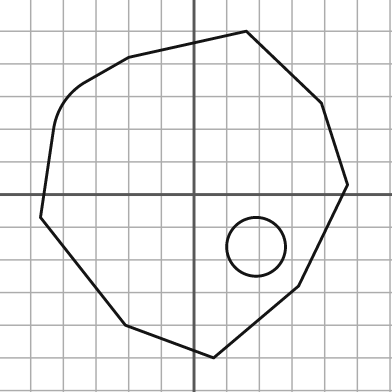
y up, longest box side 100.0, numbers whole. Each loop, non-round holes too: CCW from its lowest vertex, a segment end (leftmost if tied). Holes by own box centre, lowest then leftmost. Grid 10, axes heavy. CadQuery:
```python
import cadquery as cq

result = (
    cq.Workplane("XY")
    .moveTo(6.0, -50.0)
    .lineTo(32.0, -28.0)
    .lineTo(47.0, 3.0)
    .lineTo(39.0, 28.0)
    .lineTo(16.0, 50.0)
    .lineTo(-20.0, 42.0)
    .lineTo(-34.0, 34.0)
    .threePointArc((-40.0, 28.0), (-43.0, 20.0))
    .lineTo(-47.0, -7.0)
    .lineTo(-21.0, -40.0)
    .close()
    .moveTo(19.0, -16.0)
    .circle(9.0)
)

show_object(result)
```